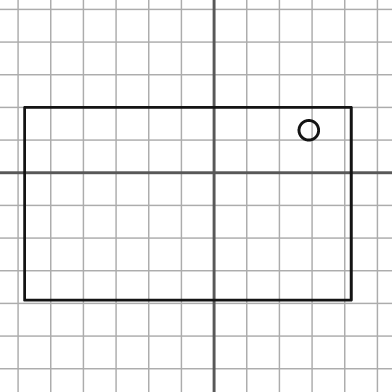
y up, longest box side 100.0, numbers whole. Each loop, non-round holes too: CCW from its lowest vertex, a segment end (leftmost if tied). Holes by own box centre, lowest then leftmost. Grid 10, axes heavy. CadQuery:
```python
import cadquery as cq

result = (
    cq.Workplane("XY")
    .moveTo(-58.0, -39.0)
    .lineTo(42.0, -39.0)
    .lineTo(42.0, 20.0)
    .lineTo(-58.0, 20.0)
    .close()
    .moveTo(29.0, 13.0)
    .circle(3.0)
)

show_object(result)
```